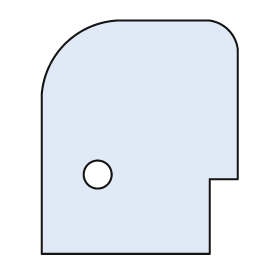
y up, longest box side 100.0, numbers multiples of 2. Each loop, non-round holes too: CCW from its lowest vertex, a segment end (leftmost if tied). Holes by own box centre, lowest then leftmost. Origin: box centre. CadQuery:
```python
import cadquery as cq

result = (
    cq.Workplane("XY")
    .moveTo(-42.0, -50.0)
    .lineTo(30.0, -50.0)
    .lineTo(30.0, -18.0)
    .lineTo(42.0, -18.0)
    .lineTo(42.0, 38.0)
    .threePointArc((38.0, 46.0), (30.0, 50.0))
    .lineTo(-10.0, 50.0)
    .threePointArc((-32.0, 40.0), (-42.0, 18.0))
    .close()
    .moveTo(-18.0, -16.0)
    .circle(6.0)
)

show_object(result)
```